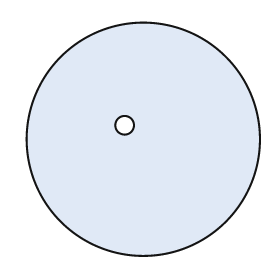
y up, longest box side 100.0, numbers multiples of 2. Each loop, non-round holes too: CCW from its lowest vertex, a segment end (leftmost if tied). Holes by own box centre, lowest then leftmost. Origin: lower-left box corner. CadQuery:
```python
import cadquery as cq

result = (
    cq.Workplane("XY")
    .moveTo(50.0, 50.0)
    .circle(50.0)
    .moveTo(42.0, 56.0)
    .circle(4.0)
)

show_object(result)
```